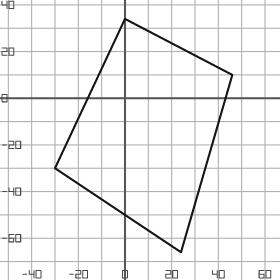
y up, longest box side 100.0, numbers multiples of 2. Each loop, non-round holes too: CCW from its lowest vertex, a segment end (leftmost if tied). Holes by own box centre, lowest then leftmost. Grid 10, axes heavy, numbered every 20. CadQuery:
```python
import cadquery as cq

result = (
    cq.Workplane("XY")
    .moveTo(24.0, -66.0)
    .lineTo(46.0, 10.0)
    .lineTo(0.0, 34.0)
    .lineTo(-30.0, -30.0)
    .close()
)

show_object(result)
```